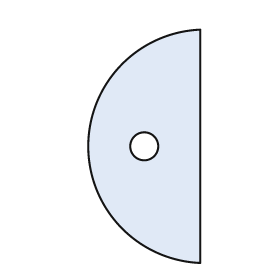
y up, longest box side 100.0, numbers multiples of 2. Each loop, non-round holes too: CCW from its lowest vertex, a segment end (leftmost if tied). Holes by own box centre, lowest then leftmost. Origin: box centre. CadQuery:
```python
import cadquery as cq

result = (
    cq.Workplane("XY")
    .moveTo(24.0, -50.0)
    .lineTo(24.0, 50.0)
    .threePointArc((-24.0, 0.0), (24.0, -50.0))
    .close()
    .moveTo(0.0, 0.0)
    .circle(6.0)
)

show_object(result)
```